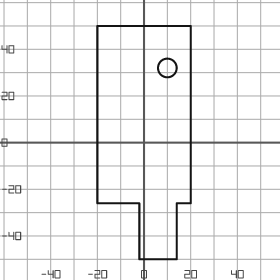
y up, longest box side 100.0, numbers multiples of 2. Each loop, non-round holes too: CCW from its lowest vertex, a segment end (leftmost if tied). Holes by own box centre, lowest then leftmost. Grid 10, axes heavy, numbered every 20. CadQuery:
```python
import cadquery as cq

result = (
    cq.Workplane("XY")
    .moveTo(-2.0, -50.0)
    .lineTo(14.0, -50.0)
    .lineTo(14.0, -26.0)
    .lineTo(20.0, -26.0)
    .lineTo(20.0, 50.0)
    .lineTo(-20.0, 50.0)
    .lineTo(-20.0, -26.0)
    .lineTo(-2.0, -26.0)
    .close()
    .moveTo(10.0, 32.0)
    .circle(4.0)
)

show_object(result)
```